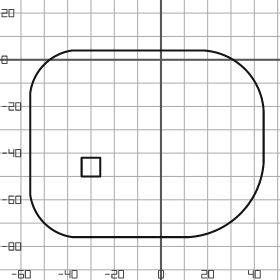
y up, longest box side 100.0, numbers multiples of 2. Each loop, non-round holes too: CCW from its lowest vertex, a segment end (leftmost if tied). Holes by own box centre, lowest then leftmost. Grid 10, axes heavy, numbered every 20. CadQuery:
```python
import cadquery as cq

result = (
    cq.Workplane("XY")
    .moveTo(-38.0, -76.0)
    .lineTo(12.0, -76.0)
    .threePointArc((34.0, -66.0), (44.0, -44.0))
    .lineTo(44.0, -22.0)
    .threePointArc((36.0, -4.0), (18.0, 4.0))
    .lineTo(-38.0, 4.0)
    .threePointArc((-50.0, -2.0), (-56.0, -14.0))
    .lineTo(-56.0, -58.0)
    .threePointArc((-50.0, -70.0), (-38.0, -76.0))
    .close()
    .moveTo(-34.0, -50.0)
    .lineTo(-26.0, -50.0)
    .lineTo(-26.0, -42.0)
    .lineTo(-34.0, -42.0)
    .close()
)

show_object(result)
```